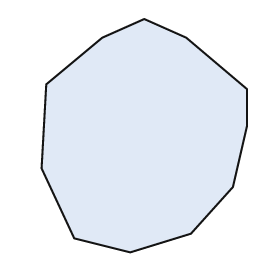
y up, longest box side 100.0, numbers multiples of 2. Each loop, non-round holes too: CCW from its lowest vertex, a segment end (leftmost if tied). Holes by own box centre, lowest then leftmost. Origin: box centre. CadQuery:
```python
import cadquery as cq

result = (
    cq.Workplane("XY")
    .moveTo(-6.0, -50.0)
    .lineTo(20.0, -42.0)
    .lineTo(38.0, -22.0)
    .lineTo(44.0, 4.0)
    .lineTo(44.0, 20.0)
    .lineTo(18.0, 42.0)
    .lineTo(0.0, 50.0)
    .lineTo(-18.0, 42.0)
    .lineTo(-42.0, 22.0)
    .lineTo(-44.0, -14.0)
    .lineTo(-30.0, -44.0)
    .close()
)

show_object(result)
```